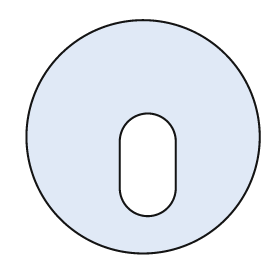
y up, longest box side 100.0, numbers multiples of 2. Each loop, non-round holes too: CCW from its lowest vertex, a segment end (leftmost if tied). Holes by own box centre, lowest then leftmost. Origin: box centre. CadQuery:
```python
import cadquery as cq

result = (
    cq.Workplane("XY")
    .moveTo(0.0, 0.0)
    .circle(50.0)
    .moveTo(-10.0, -22.0)
    .threePointArc((2.0, -34.0), (14.0, -22.0))
    .lineTo(14.0, -2.0)
    .threePointArc((2.0, 10.0), (-10.0, -2.0))
    .close()
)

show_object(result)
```